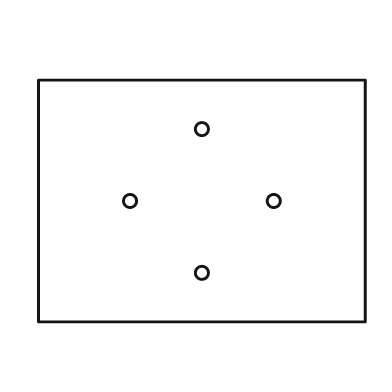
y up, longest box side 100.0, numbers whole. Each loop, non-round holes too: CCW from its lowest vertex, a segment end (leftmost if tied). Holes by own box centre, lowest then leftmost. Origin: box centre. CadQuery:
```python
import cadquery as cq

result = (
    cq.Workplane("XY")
    .moveTo(-50.0, -37.0)
    .lineTo(50.0, -37.0)
    .lineTo(50.0, 37.0)
    .lineTo(-50.0, 37.0)
    .close()
    .moveTo(0.0, -22.0)
    .circle(2.0)
    .moveTo(-22.0, 0.0)
    .circle(2.0)
    .moveTo(22.0, 0.0)
    .circle(2.0)
    .moveTo(0.0, 22.0)
    .circle(2.0)
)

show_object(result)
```